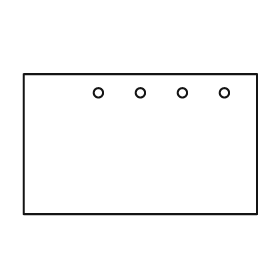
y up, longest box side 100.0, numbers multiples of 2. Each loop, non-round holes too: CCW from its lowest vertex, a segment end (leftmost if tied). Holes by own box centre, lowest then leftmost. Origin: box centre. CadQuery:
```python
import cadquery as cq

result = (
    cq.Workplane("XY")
    .moveTo(-50.0, -30.0)
    .lineTo(50.0, -30.0)
    .lineTo(50.0, 30.0)
    .lineTo(-50.0, 30.0)
    .close()
    .moveTo(-18.0, 22.0)
    .circle(2.0)
    .moveTo(0.0, 22.0)
    .circle(2.0)
    .moveTo(18.0, 22.0)
    .circle(2.0)
    .moveTo(36.0, 22.0)
    .circle(2.0)
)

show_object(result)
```